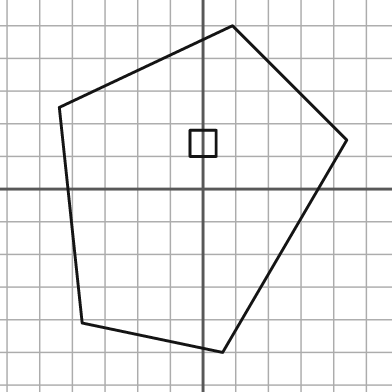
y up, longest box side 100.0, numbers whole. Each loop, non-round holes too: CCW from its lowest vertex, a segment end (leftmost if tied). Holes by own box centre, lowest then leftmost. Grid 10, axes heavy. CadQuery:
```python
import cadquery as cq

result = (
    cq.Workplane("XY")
    .moveTo(6.0, -50.0)
    .lineTo(44.0, 15.0)
    .lineTo(9.0, 50.0)
    .lineTo(-44.0, 25.0)
    .lineTo(-37.0, -41.0)
    .close()
    .moveTo(-4.0, 10.0)
    .lineTo(4.0, 10.0)
    .lineTo(4.0, 18.0)
    .lineTo(-4.0, 18.0)
    .close()
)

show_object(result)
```